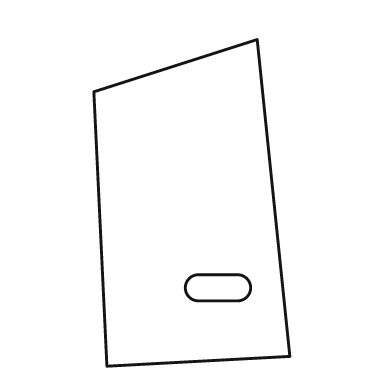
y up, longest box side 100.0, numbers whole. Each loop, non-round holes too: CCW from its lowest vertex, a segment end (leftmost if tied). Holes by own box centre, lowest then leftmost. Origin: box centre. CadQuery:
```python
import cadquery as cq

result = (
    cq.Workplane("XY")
    .moveTo(-26.0, -50.0)
    .lineTo(30.0, -47.0)
    .lineTo(20.0, 50.0)
    .lineTo(-30.0, 34.0)
    .close()
    .moveTo(2.0, -30.0)
    .lineTo(14.0, -30.0)
    .threePointArc((18.0, -26.0), (14.0, -22.0))
    .lineTo(2.0, -22.0)
    .threePointArc((-2.0, -26.0), (2.0, -30.0))
    .close()
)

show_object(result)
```